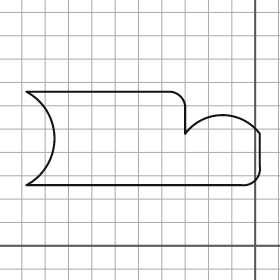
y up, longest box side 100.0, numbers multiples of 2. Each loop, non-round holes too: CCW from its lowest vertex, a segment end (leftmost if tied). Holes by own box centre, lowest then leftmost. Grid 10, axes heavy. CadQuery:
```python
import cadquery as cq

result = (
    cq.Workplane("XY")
    .moveTo(-98.0, 26.0)
    .lineTo(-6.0, 26.0)
    .threePointArc((0.0, 28.0), (2.0, 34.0))
    .lineTo(2.0, 48.0)
    .threePointArc((-14.0, 56.0), (-30.0, 48.0))
    .lineTo(-30.0, 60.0)
    .threePointArc((-32.0, 64.0), (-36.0, 66.0))
    .lineTo(-98.0, 66.0)
    .threePointArc((-86.0, 46.0), (-98.0, 26.0))
    .close()
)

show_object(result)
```